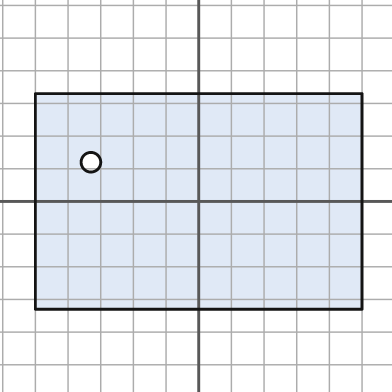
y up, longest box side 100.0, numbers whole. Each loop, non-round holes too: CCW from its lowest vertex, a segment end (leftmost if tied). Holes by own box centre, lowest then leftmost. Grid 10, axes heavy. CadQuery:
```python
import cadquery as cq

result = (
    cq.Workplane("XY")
    .moveTo(-50.0, -33.0)
    .lineTo(50.0, -33.0)
    .lineTo(50.0, 33.0)
    .lineTo(-50.0, 33.0)
    .close()
    .moveTo(-33.0, 12.0)
    .circle(3.0)
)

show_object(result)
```